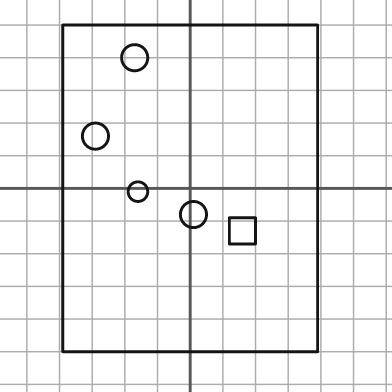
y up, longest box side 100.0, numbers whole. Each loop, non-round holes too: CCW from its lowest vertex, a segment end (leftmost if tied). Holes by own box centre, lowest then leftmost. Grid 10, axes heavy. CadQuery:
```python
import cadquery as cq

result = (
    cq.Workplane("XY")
    .moveTo(-39.0, -50.0)
    .lineTo(39.0, -50.0)
    .lineTo(39.0, 50.0)
    .lineTo(-39.0, 50.0)
    .close()
    .moveTo(12.0, -17.0)
    .lineTo(20.0, -17.0)
    .lineTo(20.0, -9.0)
    .lineTo(12.0, -9.0)
    .close()
    .moveTo(1.0, -8.0)
    .circle(4.0)
    .moveTo(-16.0, -1.0)
    .circle(3.0)
    .moveTo(-29.0, 16.0)
    .circle(4.0)
    .moveTo(-17.0, 40.0)
    .circle(4.0)
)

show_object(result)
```